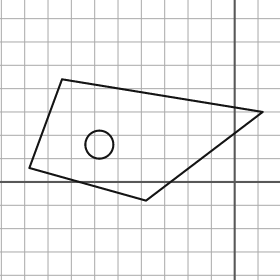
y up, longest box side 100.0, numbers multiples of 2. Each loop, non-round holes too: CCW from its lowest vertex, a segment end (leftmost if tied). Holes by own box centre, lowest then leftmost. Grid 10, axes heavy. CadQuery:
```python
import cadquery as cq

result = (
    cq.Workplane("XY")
    .moveTo(-38.0, -8.0)
    .lineTo(12.0, 30.0)
    .lineTo(-74.0, 44.0)
    .lineTo(-88.0, 6.0)
    .close()
    .moveTo(-58.0, 16.0)
    .circle(6.0)
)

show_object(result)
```